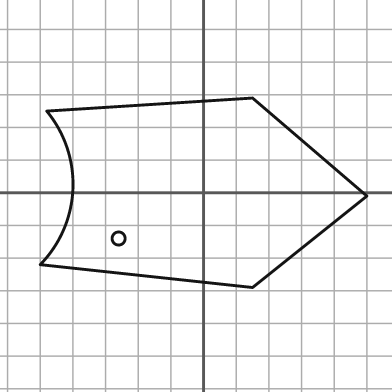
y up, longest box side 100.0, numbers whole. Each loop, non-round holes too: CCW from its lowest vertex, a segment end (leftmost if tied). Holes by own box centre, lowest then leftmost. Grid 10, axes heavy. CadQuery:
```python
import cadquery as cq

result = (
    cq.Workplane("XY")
    .moveTo(15.0, -29.0)
    .lineTo(50.0, -1.0)
    .lineTo(15.0, 29.0)
    .lineTo(-48.0, 25.0)
    .threePointArc((-40.0, 1.0), (-50.0, -22.0))
    .close()
    .moveTo(-26.0, -14.0)
    .circle(2.0)
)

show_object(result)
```